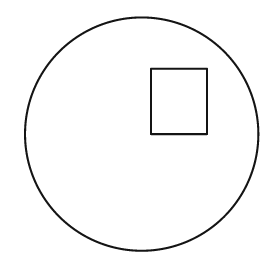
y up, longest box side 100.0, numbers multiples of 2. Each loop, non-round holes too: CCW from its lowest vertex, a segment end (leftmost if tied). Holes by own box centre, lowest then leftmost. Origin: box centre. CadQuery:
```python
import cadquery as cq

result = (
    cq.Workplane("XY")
    .moveTo(0.0, 0.0)
    .circle(50.0)
    .moveTo(4.0, 0.0)
    .lineTo(28.0, 0.0)
    .lineTo(28.0, 28.0)
    .lineTo(4.0, 28.0)
    .close()
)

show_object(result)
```